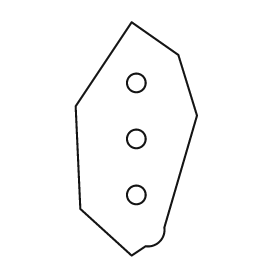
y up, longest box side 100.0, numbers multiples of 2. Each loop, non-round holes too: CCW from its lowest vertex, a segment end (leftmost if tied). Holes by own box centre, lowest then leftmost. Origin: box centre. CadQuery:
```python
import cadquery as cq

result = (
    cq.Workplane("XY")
    .moveTo(-2.0, -50.0)
    .lineTo(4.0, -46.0)
    .threePointArc((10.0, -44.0), (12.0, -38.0))
    .lineTo(26.0, 10.0)
    .lineTo(18.0, 36.0)
    .lineTo(-2.0, 50.0)
    .lineTo(-26.0, 14.0)
    .lineTo(-24.0, -30.0)
    .close()
    .moveTo(0.0, -24.0)
    .circle(4.0)
    .moveTo(0.0, 0.0)
    .circle(4.0)
    .moveTo(0.0, 24.0)
    .circle(4.0)
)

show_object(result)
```